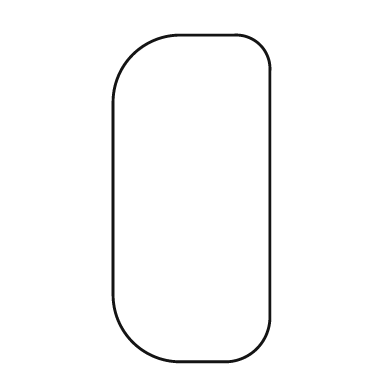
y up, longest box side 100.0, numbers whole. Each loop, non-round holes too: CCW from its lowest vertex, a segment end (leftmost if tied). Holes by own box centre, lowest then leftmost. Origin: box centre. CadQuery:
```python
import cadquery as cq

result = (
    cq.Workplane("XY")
    .moveTo(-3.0, -50.0)
    .lineTo(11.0, -50.0)
    .threePointArc((20.0, -46.0), (24.0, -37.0))
    .lineTo(24.0, 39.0)
    .threePointArc((21.0, 47.0), (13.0, 50.0))
    .lineTo(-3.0, 50.0)
    .threePointArc((-18.0, 44.0), (-24.0, 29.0))
    .lineTo(-24.0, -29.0)
    .threePointArc((-18.0, -44.0), (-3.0, -50.0))
    .close()
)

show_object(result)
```